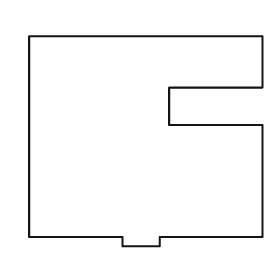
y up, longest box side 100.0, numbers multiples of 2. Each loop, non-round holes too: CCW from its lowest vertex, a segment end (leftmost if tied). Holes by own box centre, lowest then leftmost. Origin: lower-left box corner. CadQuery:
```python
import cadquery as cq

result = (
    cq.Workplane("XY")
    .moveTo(40.0, 0.0)
    .lineTo(56.0, 0.0)
    .lineTo(56.0, 4.0)
    .lineTo(100.0, 4.0)
    .lineTo(100.0, 52.0)
    .lineTo(60.0, 52.0)
    .lineTo(60.0, 68.0)
    .lineTo(100.0, 68.0)
    .lineTo(100.0, 90.0)
    .lineTo(0.0, 90.0)
    .lineTo(0.0, 4.0)
    .lineTo(40.0, 4.0)
    .close()
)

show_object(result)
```